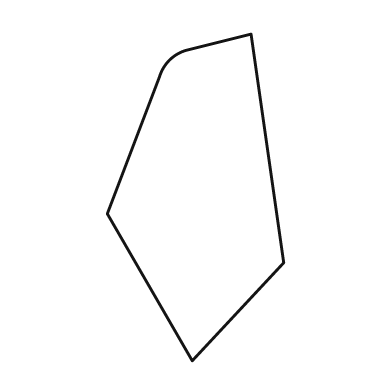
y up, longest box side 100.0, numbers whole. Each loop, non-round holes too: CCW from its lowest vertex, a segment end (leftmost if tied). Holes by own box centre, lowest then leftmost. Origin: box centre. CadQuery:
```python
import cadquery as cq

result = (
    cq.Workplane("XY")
    .moveTo(-1.0, -50.0)
    .lineTo(27.0, -20.0)
    .lineTo(17.0, 50.0)
    .lineTo(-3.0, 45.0)
    .threePointArc((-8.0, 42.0), (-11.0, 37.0))
    .lineTo(-27.0, -5.0)
    .close()
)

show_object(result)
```